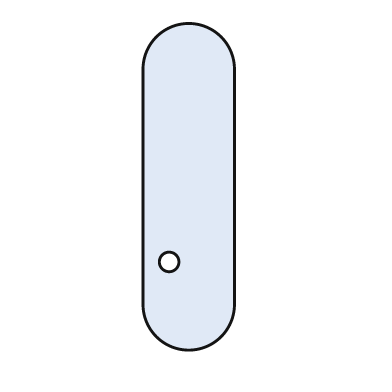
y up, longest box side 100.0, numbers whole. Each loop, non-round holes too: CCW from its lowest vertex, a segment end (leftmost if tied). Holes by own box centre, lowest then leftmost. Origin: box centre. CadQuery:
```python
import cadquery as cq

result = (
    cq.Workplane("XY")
    .moveTo(-14.0, -36.0)
    .threePointArc((0.0, -50.0), (14.0, -36.0))
    .lineTo(14.0, 36.0)
    .threePointArc((0.0, 50.0), (-14.0, 36.0))
    .close()
    .moveTo(-6.0, -23.0)
    .circle(3.0)
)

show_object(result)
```